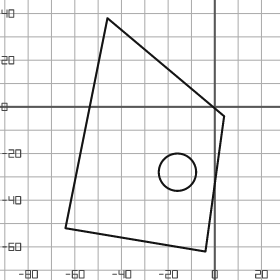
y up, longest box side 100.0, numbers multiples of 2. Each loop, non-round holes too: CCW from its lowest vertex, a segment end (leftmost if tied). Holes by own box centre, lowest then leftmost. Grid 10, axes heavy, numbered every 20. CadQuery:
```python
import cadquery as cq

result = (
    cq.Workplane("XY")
    .moveTo(-4.0, -62.0)
    .lineTo(4.0, -4.0)
    .lineTo(-46.0, 38.0)
    .lineTo(-64.0, -52.0)
    .close()
    .moveTo(-16.0, -28.0)
    .circle(8.0)
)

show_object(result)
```